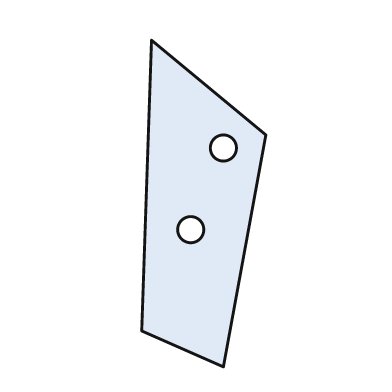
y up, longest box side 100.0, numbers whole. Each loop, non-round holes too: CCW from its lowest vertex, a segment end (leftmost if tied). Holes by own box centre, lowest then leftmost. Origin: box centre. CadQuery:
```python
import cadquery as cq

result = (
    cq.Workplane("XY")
    .moveTo(6.0, -50.0)
    .lineTo(19.0, 21.0)
    .lineTo(-16.0, 50.0)
    .lineTo(-19.0, -39.0)
    .close()
    .moveTo(-4.0, -8.0)
    .circle(4.0)
    .moveTo(6.0, 17.0)
    .circle(4.0)
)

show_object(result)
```